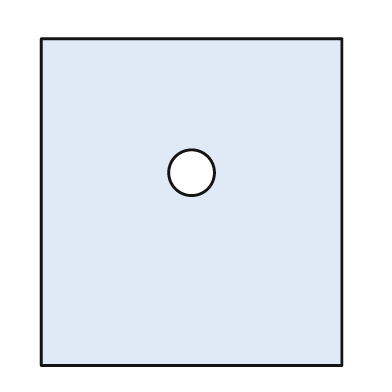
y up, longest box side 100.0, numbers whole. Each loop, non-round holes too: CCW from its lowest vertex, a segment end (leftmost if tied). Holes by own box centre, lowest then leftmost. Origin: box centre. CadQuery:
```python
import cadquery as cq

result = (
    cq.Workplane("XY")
    .moveTo(-46.0, -50.0)
    .lineTo(46.0, -50.0)
    .lineTo(46.0, 50.0)
    .lineTo(-46.0, 50.0)
    .close()
    .moveTo(0.0, 9.0)
    .circle(7.0)
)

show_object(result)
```